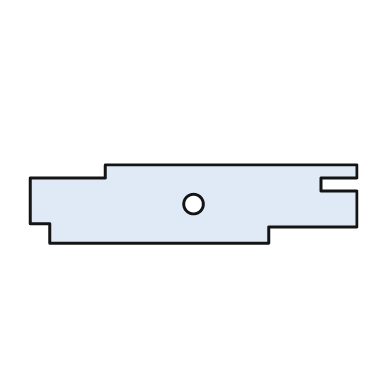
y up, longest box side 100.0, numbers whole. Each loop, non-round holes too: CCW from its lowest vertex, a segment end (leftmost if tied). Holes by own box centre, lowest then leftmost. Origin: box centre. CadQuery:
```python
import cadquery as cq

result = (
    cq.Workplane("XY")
    .moveTo(-44.0, -12.0)
    .lineTo(23.0, -12.0)
    .lineTo(23.0, -7.0)
    .lineTo(50.0, -7.0)
    .lineTo(50.0, 4.0)
    .lineTo(39.0, 4.0)
    .lineTo(39.0, 8.0)
    .lineTo(50.0, 8.0)
    .lineTo(50.0, 12.0)
    .lineTo(-27.0, 12.0)
    .lineTo(-27.0, 8.0)
    .lineTo(-50.0, 8.0)
    .lineTo(-50.0, -6.0)
    .lineTo(-44.0, -6.0)
    .close()
    .moveTo(0.0, 0.0)
    .circle(3.0)
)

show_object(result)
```